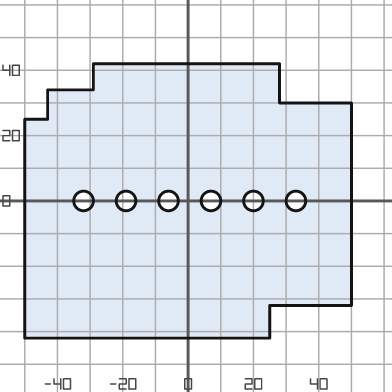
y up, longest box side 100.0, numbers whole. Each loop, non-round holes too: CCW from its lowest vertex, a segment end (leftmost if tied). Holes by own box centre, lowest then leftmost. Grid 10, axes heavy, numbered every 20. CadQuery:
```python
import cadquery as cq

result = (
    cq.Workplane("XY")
    .moveTo(-50.0, -42.0)
    .lineTo(25.0, -42.0)
    .lineTo(25.0, -32.0)
    .lineTo(50.0, -32.0)
    .lineTo(50.0, 30.0)
    .lineTo(28.0, 30.0)
    .lineTo(28.0, 42.0)
    .lineTo(-29.0, 42.0)
    .lineTo(-29.0, 34.0)
    .lineTo(-43.0, 34.0)
    .lineTo(-43.0, 25.0)
    .lineTo(-50.0, 25.0)
    .close()
    .moveTo(-32.0, 0.0)
    .circle(3.0)
    .moveTo(-19.0, 0.0)
    .circle(3.0)
    .moveTo(-6.0, 0.0)
    .circle(3.0)
    .moveTo(7.0, 0.0)
    .circle(3.0)
    .moveTo(20.0, 0.0)
    .circle(3.0)
    .moveTo(33.0, 0.0)
    .circle(3.0)
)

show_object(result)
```